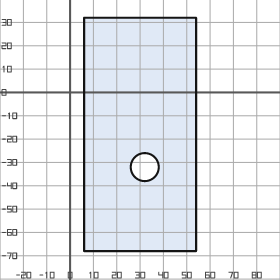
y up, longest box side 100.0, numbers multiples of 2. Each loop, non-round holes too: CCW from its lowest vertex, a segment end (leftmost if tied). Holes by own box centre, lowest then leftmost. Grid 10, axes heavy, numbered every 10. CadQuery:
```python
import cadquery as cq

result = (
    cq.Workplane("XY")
    .moveTo(6.0, -68.0)
    .lineTo(54.0, -68.0)
    .lineTo(54.0, 32.0)
    .lineTo(6.0, 32.0)
    .close()
    .moveTo(32.0, -32.0)
    .circle(6.0)
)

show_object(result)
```